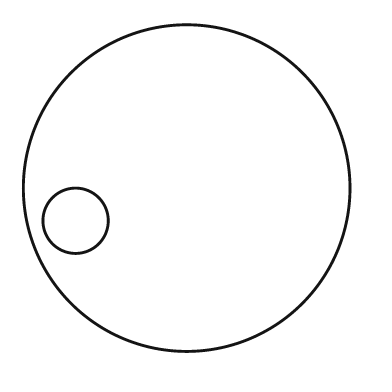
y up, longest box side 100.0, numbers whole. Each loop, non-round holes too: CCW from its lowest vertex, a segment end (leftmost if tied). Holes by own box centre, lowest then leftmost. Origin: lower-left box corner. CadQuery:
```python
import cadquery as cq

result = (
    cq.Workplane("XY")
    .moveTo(50.0, 50.0)
    .circle(50.0)
    .moveTo(16.0, 40.0)
    .circle(10.0)
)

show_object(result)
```